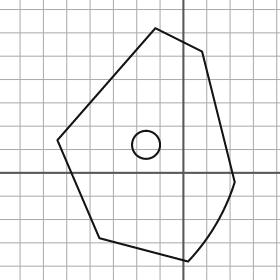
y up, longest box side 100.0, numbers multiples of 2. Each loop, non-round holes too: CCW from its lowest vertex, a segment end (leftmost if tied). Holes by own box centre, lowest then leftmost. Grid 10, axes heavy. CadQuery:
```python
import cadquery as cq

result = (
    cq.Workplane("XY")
    .moveTo(2.0, -38.0)
    .threePointArc((14.0, -22.0), (22.0, -4.0))
    .lineTo(8.0, 52.0)
    .lineTo(-12.0, 62.0)
    .lineTo(-54.0, 14.0)
    .lineTo(-36.0, -28.0)
    .close()
    .moveTo(-16.0, 12.0)
    .circle(6.0)
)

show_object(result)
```